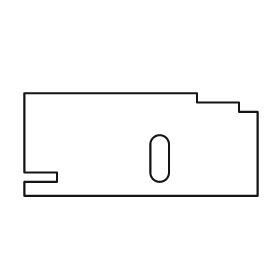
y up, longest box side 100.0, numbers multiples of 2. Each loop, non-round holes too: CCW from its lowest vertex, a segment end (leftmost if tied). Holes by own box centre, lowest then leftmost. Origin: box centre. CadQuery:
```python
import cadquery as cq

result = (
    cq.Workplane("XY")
    .moveTo(-50.0, -22.0)
    .lineTo(50.0, -22.0)
    .lineTo(50.0, 14.0)
    .lineTo(42.0, 14.0)
    .lineTo(42.0, 18.0)
    .lineTo(24.0, 18.0)
    .lineTo(24.0, 22.0)
    .lineTo(-50.0, 22.0)
    .lineTo(-50.0, -12.0)
    .lineTo(-36.0, -12.0)
    .lineTo(-36.0, -16.0)
    .lineTo(-50.0, -16.0)
    .close()
    .moveTo(4.0, -12.0)
    .threePointArc((8.0, -16.0), (12.0, -12.0))
    .lineTo(12.0, 0.0)
    .threePointArc((8.0, 4.0), (4.0, 0.0))
    .close()
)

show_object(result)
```